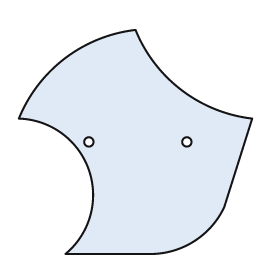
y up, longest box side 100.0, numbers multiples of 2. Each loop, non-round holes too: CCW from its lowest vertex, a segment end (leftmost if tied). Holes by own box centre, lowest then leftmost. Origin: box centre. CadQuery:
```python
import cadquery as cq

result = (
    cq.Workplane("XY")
    .moveTo(-30.0, -48.0)
    .lineTo(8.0, -48.0)
    .threePointArc((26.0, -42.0), (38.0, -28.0))
    .lineTo(50.0, 10.0)
    .threePointArc((20.0, 22.0), (0.0, 48.0))
    .threePointArc((-30.0, 36.0), (-50.0, 10.0))
    .threePointArc((-20.0, -12.0), (-30.0, -48.0))
    .close()
    .moveTo(-20.0, 0.0)
    .circle(2.0)
    .moveTo(22.0, 0.0)
    .circle(2.0)
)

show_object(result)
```